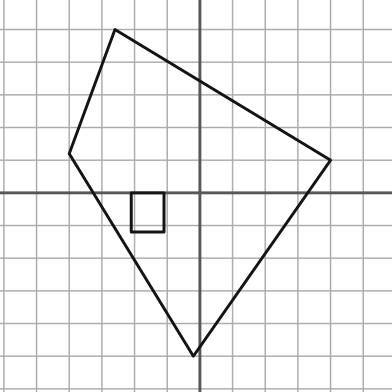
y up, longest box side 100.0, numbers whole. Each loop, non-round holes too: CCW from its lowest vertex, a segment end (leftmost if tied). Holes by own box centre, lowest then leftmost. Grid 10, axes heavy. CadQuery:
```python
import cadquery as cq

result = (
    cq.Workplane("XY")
    .moveTo(-2.0, -50.0)
    .lineTo(40.0, 10.0)
    .lineTo(-26.0, 50.0)
    .lineTo(-40.0, 12.0)
    .close()
    .moveTo(-21.0, -12.0)
    .lineTo(-11.0, -12.0)
    .lineTo(-11.0, 0.0)
    .lineTo(-21.0, 0.0)
    .close()
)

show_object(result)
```